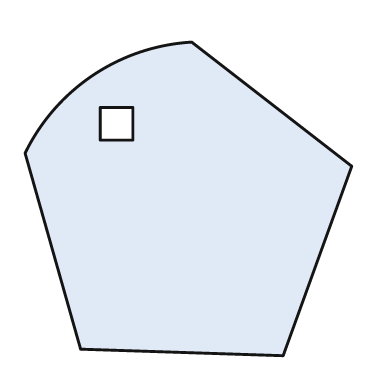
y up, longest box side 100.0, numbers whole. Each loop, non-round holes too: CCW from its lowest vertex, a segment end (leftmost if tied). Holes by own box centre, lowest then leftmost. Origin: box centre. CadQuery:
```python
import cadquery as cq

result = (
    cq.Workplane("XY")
    .moveTo(29.0, -48.0)
    .lineTo(50.0, 10.0)
    .lineTo(1.0, 48.0)
    .threePointArc((-29.0, 38.0), (-50.0, 14.0))
    .lineTo(-33.0, -46.0)
    .close()
    .moveTo(-27.0, 18.0)
    .lineTo(-17.0, 18.0)
    .lineTo(-17.0, 28.0)
    .lineTo(-27.0, 28.0)
    .close()
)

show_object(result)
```